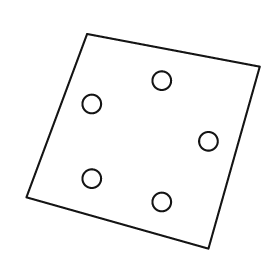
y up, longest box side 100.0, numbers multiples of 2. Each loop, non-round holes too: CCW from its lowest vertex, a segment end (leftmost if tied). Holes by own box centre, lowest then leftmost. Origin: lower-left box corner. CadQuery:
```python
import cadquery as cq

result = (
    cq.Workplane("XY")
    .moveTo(78.0, 0.0)
    .lineTo(100.0, 78.0)
    .lineTo(26.0, 92.0)
    .lineTo(0.0, 22.0)
    .close()
    .moveTo(58.0, 20.0)
    .circle(4.0)
    .moveTo(28.0, 30.0)
    .circle(4.0)
    .moveTo(78.0, 46.0)
    .circle(4.0)
    .moveTo(28.0, 62.0)
    .circle(4.0)
    .moveTo(58.0, 72.0)
    .circle(4.0)
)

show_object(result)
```